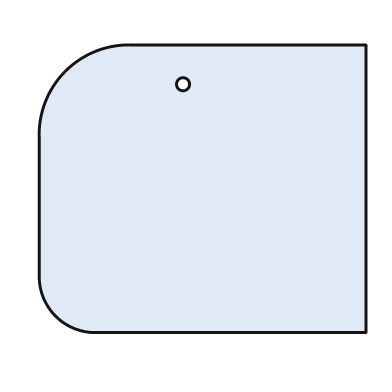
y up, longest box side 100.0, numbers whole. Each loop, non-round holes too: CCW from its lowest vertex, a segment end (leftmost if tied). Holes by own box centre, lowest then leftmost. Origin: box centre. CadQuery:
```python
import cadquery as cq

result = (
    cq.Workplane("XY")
    .moveTo(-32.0, -44.0)
    .lineTo(50.0, -44.0)
    .lineTo(50.0, 44.0)
    .lineTo(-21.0, 44.0)
    .threePointArc((-42.0, 36.0), (-50.0, 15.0))
    .lineTo(-50.0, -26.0)
    .threePointArc((-45.0, -39.0), (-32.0, -44.0))
    .close()
    .moveTo(-6.0, 32.0)
    .circle(2.0)
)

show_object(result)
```